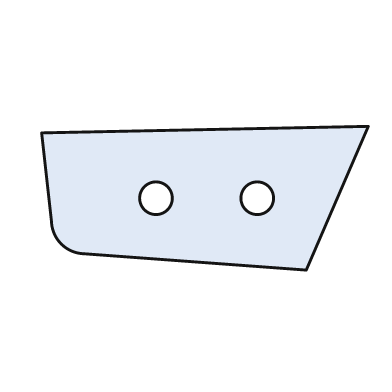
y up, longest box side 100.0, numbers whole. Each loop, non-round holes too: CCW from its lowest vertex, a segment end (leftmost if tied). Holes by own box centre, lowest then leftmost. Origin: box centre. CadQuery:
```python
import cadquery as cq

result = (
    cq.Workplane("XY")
    .moveTo(31.0, -22.0)
    .lineTo(50.0, 22.0)
    .lineTo(-50.0, 20.0)
    .lineTo(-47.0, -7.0)
    .threePointArc((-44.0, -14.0), (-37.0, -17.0))
    .close()
    .moveTo(-15.0, 0.0)
    .circle(5.0)
    .moveTo(16.0, 0.0)
    .circle(5.0)
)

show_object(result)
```